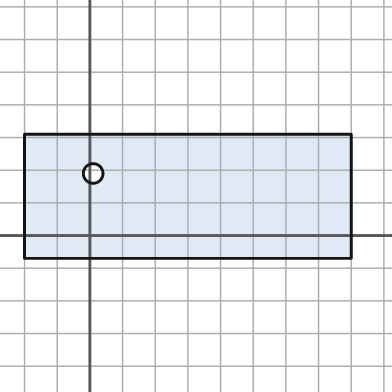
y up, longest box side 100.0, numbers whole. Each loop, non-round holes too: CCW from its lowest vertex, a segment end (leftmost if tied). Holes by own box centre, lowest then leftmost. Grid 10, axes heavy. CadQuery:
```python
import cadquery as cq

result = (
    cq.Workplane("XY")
    .moveTo(-20.0, -7.0)
    .lineTo(80.0, -7.0)
    .lineTo(80.0, 31.0)
    .lineTo(-20.0, 31.0)
    .close()
    .moveTo(1.0, 19.0)
    .circle(3.0)
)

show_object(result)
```